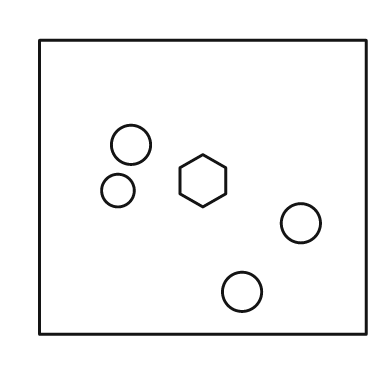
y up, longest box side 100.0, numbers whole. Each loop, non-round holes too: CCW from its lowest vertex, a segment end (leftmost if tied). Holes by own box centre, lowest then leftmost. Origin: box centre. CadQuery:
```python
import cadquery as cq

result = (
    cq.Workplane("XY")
    .moveTo(-50.0, -45.0)
    .lineTo(50.0, -45.0)
    .lineTo(50.0, 45.0)
    .lineTo(-50.0, 45.0)
    .close()
    .moveTo(12.0, -32.0)
    .circle(6.0)
    .moveTo(30.0, -11.0)
    .circle(6.0)
    .moveTo(-26.0, -1.0)
    .circle(5.0)
    .moveTo(0.0, -6.0)
    .lineTo(7.0, -2.0)
    .lineTo(7.0, 6.0)
    .lineTo(0.0, 10.0)
    .lineTo(-7.0, 6.0)
    .lineTo(-7.0, -2.0)
    .close()
    .moveTo(-22.0, 13.0)
    .circle(6.0)
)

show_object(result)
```